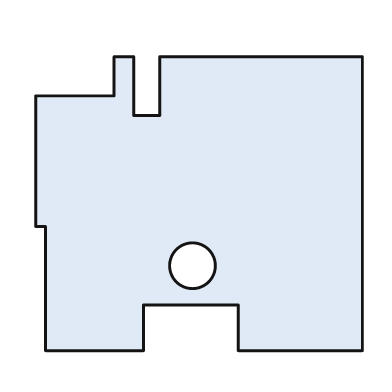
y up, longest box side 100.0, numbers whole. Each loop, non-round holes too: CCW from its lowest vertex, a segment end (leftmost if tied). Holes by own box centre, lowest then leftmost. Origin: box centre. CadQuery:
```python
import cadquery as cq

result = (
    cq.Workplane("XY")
    .moveTo(-47.0, -45.0)
    .lineTo(-17.0, -45.0)
    .lineTo(-17.0, -31.0)
    .lineTo(12.0, -31.0)
    .lineTo(12.0, -45.0)
    .lineTo(50.0, -45.0)
    .lineTo(50.0, 45.0)
    .lineTo(-12.0, 45.0)
    .lineTo(-12.0, 27.0)
    .lineTo(-20.0, 27.0)
    .lineTo(-20.0, 45.0)
    .lineTo(-26.0, 45.0)
    .lineTo(-26.0, 33.0)
    .lineTo(-50.0, 33.0)
    .lineTo(-50.0, -7.0)
    .lineTo(-47.0, -7.0)
    .close()
    .moveTo(-2.0, -19.0)
    .circle(7.0)
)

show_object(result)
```